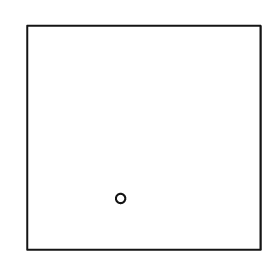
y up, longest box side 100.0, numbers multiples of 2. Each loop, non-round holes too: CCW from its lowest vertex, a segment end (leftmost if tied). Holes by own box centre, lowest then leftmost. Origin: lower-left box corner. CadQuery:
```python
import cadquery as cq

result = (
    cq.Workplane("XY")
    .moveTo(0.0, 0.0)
    .lineTo(100.0, 0.0)
    .lineTo(100.0, 96.0)
    .lineTo(0.0, 96.0)
    .close()
    .moveTo(40.0, 22.0)
    .circle(2.0)
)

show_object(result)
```